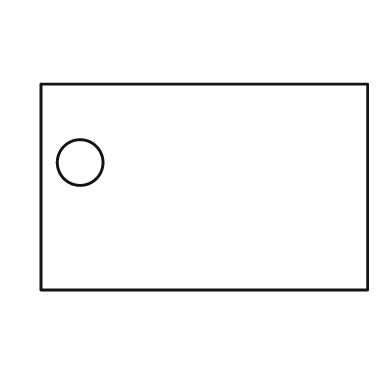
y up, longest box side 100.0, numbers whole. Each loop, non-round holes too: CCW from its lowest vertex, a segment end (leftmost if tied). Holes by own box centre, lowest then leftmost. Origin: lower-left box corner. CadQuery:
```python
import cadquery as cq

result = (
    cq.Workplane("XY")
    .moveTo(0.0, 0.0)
    .lineTo(100.0, 0.0)
    .lineTo(100.0, 63.0)
    .lineTo(0.0, 63.0)
    .close()
    .moveTo(12.0, 39.0)
    .circle(7.0)
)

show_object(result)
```